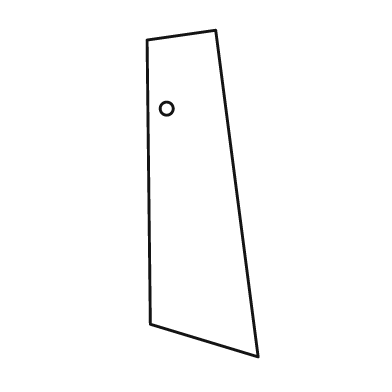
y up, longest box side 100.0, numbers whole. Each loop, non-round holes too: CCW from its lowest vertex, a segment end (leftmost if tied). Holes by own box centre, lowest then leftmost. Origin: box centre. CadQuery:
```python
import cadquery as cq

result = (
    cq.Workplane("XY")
    .moveTo(17.0, -50.0)
    .lineTo(4.0, 50.0)
    .lineTo(-17.0, 47.0)
    .lineTo(-16.0, -40.0)
    .close()
    .moveTo(-11.0, 26.0)
    .circle(2.0)
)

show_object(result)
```